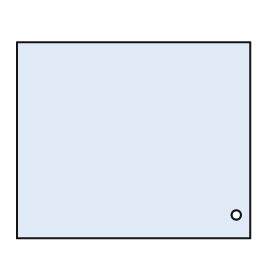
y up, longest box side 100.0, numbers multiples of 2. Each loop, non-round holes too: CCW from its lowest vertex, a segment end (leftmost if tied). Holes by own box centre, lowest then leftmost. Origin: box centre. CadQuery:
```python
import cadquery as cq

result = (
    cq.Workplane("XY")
    .moveTo(-50.0, -42.0)
    .lineTo(50.0, -42.0)
    .lineTo(50.0, 42.0)
    .lineTo(-50.0, 42.0)
    .close()
    .moveTo(44.0, -32.0)
    .circle(2.0)
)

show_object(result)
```